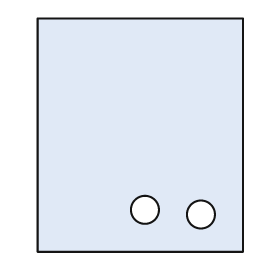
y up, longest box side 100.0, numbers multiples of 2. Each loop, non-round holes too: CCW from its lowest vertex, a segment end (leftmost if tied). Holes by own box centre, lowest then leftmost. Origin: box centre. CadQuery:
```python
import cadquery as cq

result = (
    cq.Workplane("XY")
    .moveTo(-44.0, -50.0)
    .lineTo(44.0, -50.0)
    .lineTo(44.0, 50.0)
    .lineTo(-44.0, 50.0)
    .close()
    .moveTo(26.0, -34.0)
    .circle(6.0)
    .moveTo(2.0, -32.0)
    .circle(6.0)
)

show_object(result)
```